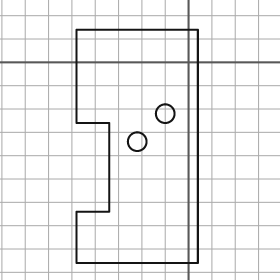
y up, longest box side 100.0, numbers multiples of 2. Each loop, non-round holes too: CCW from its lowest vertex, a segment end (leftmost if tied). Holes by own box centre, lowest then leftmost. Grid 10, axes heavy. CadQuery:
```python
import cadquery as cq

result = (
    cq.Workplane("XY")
    .moveTo(-48.0, -86.0)
    .lineTo(4.0, -86.0)
    .lineTo(4.0, 14.0)
    .lineTo(-48.0, 14.0)
    .lineTo(-48.0, -26.0)
    .lineTo(-34.0, -26.0)
    .lineTo(-34.0, -64.0)
    .lineTo(-48.0, -64.0)
    .close()
    .moveTo(-22.0, -34.0)
    .circle(4.0)
    .moveTo(-10.0, -22.0)
    .circle(4.0)
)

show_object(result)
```